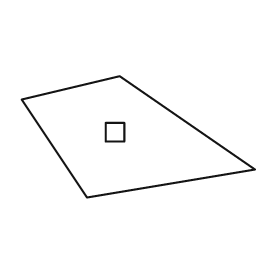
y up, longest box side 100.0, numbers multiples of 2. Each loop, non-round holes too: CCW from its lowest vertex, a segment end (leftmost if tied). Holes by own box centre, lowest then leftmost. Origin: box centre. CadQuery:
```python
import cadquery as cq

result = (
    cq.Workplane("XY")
    .moveTo(-22.0, -26.0)
    .lineTo(50.0, -14.0)
    .lineTo(-8.0, 26.0)
    .lineTo(-50.0, 16.0)
    .close()
    .moveTo(-14.0, -2.0)
    .lineTo(-6.0, -2.0)
    .lineTo(-6.0, 6.0)
    .lineTo(-14.0, 6.0)
    .close()
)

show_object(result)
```